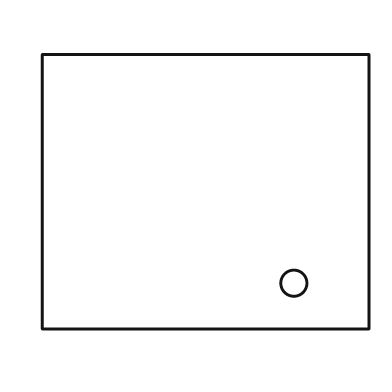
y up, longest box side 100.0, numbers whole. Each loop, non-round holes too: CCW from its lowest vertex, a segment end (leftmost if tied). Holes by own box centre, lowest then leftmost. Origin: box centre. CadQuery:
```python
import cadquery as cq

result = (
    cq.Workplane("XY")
    .moveTo(-50.0, -42.0)
    .lineTo(50.0, -42.0)
    .lineTo(50.0, 42.0)
    .lineTo(-50.0, 42.0)
    .close()
    .moveTo(27.0, -28.0)
    .circle(4.0)
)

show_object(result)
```